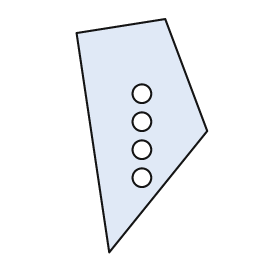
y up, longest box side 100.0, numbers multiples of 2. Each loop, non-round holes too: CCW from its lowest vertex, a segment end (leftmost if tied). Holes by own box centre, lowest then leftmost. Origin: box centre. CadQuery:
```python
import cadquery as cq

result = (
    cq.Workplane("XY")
    .moveTo(-14.0, -50.0)
    .lineTo(28.0, 2.0)
    .lineTo(10.0, 50.0)
    .lineTo(-28.0, 44.0)
    .close()
    .moveTo(0.0, -18.0)
    .circle(4.0)
    .moveTo(0.0, -6.0)
    .circle(4.0)
    .moveTo(0.0, 6.0)
    .circle(4.0)
    .moveTo(0.0, 18.0)
    .circle(4.0)
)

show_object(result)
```